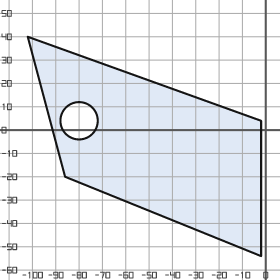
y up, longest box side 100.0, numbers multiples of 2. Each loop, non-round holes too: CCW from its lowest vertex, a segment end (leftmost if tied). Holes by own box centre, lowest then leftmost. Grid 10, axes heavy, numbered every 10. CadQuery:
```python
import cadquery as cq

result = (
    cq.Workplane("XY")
    .moveTo(-2.0, -54.0)
    .lineTo(-2.0, 4.0)
    .lineTo(-102.0, 40.0)
    .lineTo(-86.0, -20.0)
    .close()
    .moveTo(-80.0, 4.0)
    .circle(8.0)
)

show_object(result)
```